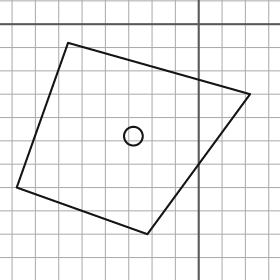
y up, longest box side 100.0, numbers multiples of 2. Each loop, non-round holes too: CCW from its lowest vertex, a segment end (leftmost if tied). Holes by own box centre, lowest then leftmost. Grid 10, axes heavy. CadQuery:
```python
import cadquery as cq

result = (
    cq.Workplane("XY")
    .moveTo(-22.0, -90.0)
    .lineTo(22.0, -30.0)
    .lineTo(-56.0, -8.0)
    .lineTo(-78.0, -70.0)
    .close()
    .moveTo(-28.0, -48.0)
    .circle(4.0)
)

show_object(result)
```